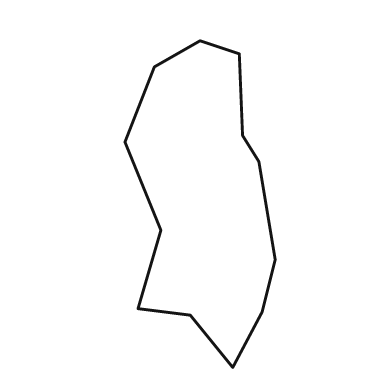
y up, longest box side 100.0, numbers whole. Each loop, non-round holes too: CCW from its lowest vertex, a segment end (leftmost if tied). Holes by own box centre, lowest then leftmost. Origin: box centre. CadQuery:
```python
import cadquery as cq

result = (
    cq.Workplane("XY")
    .moveTo(10.0, -50.0)
    .lineTo(19.0, -33.0)
    .lineTo(23.0, -17.0)
    .lineTo(18.0, 13.0)
    .lineTo(13.0, 21.0)
    .lineTo(12.0, 46.0)
    .lineTo(0.0, 50.0)
    .lineTo(-14.0, 42.0)
    .lineTo(-23.0, 19.0)
    .lineTo(-12.0, -8.0)
    .lineTo(-19.0, -32.0)
    .lineTo(-3.0, -34.0)
    .close()
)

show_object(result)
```